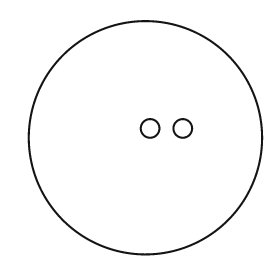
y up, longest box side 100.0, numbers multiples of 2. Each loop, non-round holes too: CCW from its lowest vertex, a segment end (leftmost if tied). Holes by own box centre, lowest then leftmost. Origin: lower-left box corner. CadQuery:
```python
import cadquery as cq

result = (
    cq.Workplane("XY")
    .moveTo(50.0, 50.0)
    .circle(50.0)
    .moveTo(52.0, 54.0)
    .circle(4.0)
    .moveTo(66.0, 54.0)
    .circle(4.0)
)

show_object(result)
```